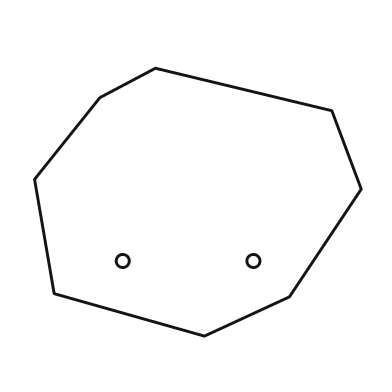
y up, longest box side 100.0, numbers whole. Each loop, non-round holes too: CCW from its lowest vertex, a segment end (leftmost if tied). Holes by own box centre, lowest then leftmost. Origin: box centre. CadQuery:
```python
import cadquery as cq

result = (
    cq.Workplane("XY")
    .moveTo(2.0, -41.0)
    .lineTo(28.0, -29.0)
    .lineTo(50.0, 4.0)
    .lineTo(41.0, 28.0)
    .lineTo(-13.0, 41.0)
    .lineTo(-30.0, 32.0)
    .lineTo(-50.0, 7.0)
    .lineTo(-44.0, -28.0)
    .close()
    .moveTo(-23.0, -18.0)
    .circle(2.0)
    .moveTo(17.0, -18.0)
    .circle(2.0)
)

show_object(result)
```